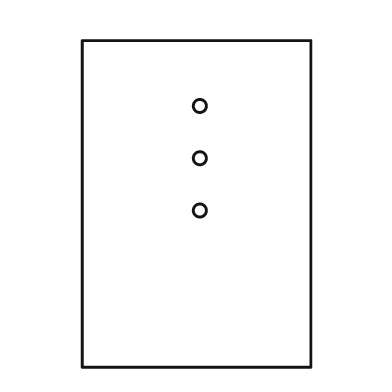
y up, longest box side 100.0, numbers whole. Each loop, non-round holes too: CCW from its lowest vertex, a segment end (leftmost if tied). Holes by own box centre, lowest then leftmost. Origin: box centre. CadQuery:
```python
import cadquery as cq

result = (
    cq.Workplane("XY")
    .moveTo(-35.0, -50.0)
    .lineTo(35.0, -50.0)
    .lineTo(35.0, 50.0)
    .lineTo(-35.0, 50.0)
    .close()
    .moveTo(1.0, -2.0)
    .circle(2.0)
    .moveTo(1.0, 14.0)
    .circle(2.0)
    .moveTo(1.0, 30.0)
    .circle(2.0)
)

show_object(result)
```